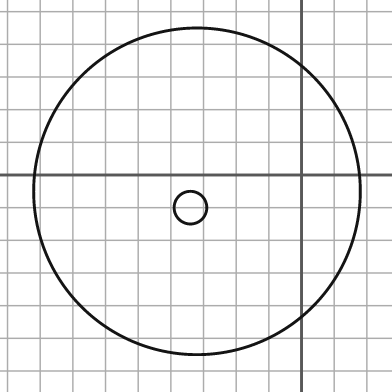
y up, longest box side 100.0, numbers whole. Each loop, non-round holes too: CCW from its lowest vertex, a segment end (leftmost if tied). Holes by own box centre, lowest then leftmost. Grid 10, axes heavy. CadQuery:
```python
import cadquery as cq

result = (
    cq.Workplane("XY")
    .moveTo(-32.0, -5.0)
    .circle(50.0)
    .moveTo(-34.0, -10.0)
    .circle(5.0)
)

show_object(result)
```